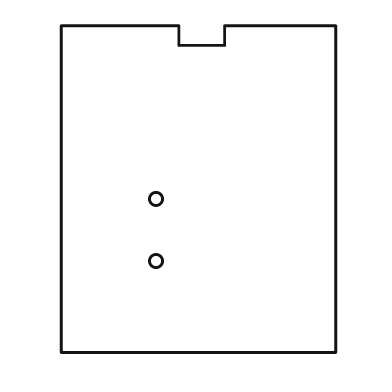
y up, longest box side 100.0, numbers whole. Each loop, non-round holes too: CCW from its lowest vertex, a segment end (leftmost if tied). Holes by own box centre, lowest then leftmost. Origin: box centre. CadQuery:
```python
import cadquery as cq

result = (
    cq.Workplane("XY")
    .moveTo(-42.0, -50.0)
    .lineTo(42.0, -50.0)
    .lineTo(42.0, 50.0)
    .lineTo(8.0, 50.0)
    .lineTo(8.0, 44.0)
    .lineTo(-6.0, 44.0)
    .lineTo(-6.0, 50.0)
    .lineTo(-42.0, 50.0)
    .close()
    .moveTo(-13.0, -22.0)
    .circle(2.0)
    .moveTo(-13.0, -3.0)
    .circle(2.0)
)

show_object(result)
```